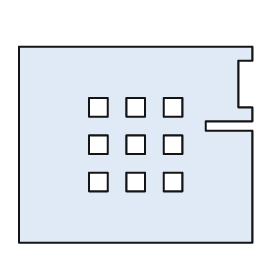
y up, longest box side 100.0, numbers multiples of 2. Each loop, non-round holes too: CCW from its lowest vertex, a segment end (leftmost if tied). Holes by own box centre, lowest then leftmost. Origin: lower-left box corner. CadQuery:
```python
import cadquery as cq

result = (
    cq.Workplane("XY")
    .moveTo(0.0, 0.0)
    .lineTo(100.0, 0.0)
    .lineTo(100.0, 48.0)
    .lineTo(80.0, 48.0)
    .lineTo(80.0, 52.0)
    .lineTo(100.0, 52.0)
    .lineTo(100.0, 58.0)
    .lineTo(94.0, 58.0)
    .lineTo(94.0, 78.0)
    .lineTo(100.0, 78.0)
    .lineTo(100.0, 84.0)
    .lineTo(0.0, 84.0)
    .close()
    .moveTo(30.0, 22.0)
    .lineTo(38.0, 22.0)
    .lineTo(38.0, 30.0)
    .lineTo(30.0, 30.0)
    .close()
    .moveTo(46.0, 22.0)
    .lineTo(54.0, 22.0)
    .lineTo(54.0, 30.0)
    .lineTo(46.0, 30.0)
    .close()
    .moveTo(62.0, 22.0)
    .lineTo(70.0, 22.0)
    .lineTo(70.0, 30.0)
    .lineTo(62.0, 30.0)
    .close()
    .moveTo(30.0, 38.0)
    .lineTo(38.0, 38.0)
    .lineTo(38.0, 46.0)
    .lineTo(30.0, 46.0)
    .close()
    .moveTo(46.0, 38.0)
    .lineTo(54.0, 38.0)
    .lineTo(54.0, 46.0)
    .lineTo(46.0, 46.0)
    .close()
    .moveTo(62.0, 38.0)
    .lineTo(70.0, 38.0)
    .lineTo(70.0, 46.0)
    .lineTo(62.0, 46.0)
    .close()
    .moveTo(30.0, 54.0)
    .lineTo(38.0, 54.0)
    .lineTo(38.0, 62.0)
    .lineTo(30.0, 62.0)
    .close()
    .moveTo(46.0, 54.0)
    .lineTo(54.0, 54.0)
    .lineTo(54.0, 62.0)
    .lineTo(46.0, 62.0)
    .close()
    .moveTo(62.0, 54.0)
    .lineTo(70.0, 54.0)
    .lineTo(70.0, 62.0)
    .lineTo(62.0, 62.0)
    .close()
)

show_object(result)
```